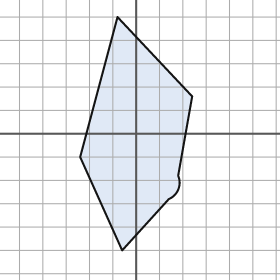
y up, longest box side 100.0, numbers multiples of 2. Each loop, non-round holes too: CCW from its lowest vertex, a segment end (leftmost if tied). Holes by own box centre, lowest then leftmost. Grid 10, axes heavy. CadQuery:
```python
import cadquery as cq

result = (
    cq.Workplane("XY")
    .moveTo(-6.0, -50.0)
    .lineTo(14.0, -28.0)
    .threePointArc((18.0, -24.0), (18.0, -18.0))
    .lineTo(24.0, 16.0)
    .lineTo(-8.0, 50.0)
    .lineTo(-24.0, -10.0)
    .close()
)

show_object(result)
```